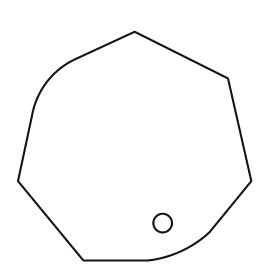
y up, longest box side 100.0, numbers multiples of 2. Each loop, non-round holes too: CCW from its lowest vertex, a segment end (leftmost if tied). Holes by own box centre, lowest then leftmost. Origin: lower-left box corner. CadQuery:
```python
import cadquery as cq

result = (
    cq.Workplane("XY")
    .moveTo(28.0, 0.0)
    .lineTo(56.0, 0.0)
    .threePointArc((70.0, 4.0), (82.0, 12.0))
    .lineTo(100.0, 34.0)
    .lineTo(90.0, 78.0)
    .lineTo(50.0, 98.0)
    .lineTo(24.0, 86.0)
    .threePointArc((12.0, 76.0), (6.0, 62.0))
    .lineTo(0.0, 34.0)
    .close()
    .moveTo(62.0, 16.0)
    .circle(4.0)
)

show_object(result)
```